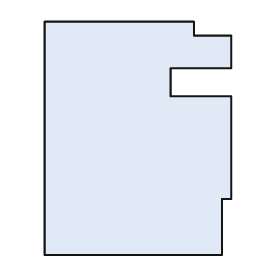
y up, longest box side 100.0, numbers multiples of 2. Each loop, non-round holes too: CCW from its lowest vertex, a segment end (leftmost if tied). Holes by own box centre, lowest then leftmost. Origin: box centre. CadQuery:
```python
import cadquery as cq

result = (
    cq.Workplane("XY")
    .moveTo(-40.0, -50.0)
    .lineTo(36.0, -50.0)
    .lineTo(36.0, -26.0)
    .lineTo(40.0, -26.0)
    .lineTo(40.0, 18.0)
    .lineTo(14.0, 18.0)
    .lineTo(14.0, 30.0)
    .lineTo(40.0, 30.0)
    .lineTo(40.0, 44.0)
    .lineTo(24.0, 44.0)
    .lineTo(24.0, 50.0)
    .lineTo(-40.0, 50.0)
    .close()
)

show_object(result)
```